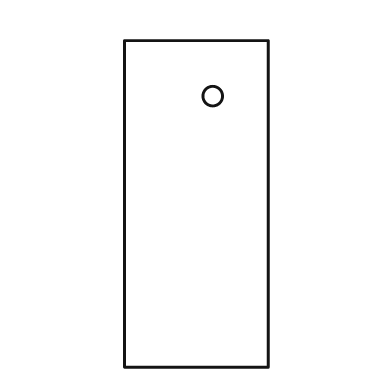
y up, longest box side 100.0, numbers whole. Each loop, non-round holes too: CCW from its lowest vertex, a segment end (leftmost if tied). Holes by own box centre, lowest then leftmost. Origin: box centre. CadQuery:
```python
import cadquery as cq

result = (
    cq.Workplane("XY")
    .moveTo(-22.0, -50.0)
    .lineTo(22.0, -50.0)
    .lineTo(22.0, 50.0)
    .lineTo(-22.0, 50.0)
    .close()
    .moveTo(5.0, 33.0)
    .circle(3.0)
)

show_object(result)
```